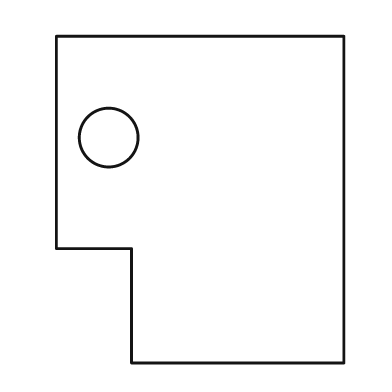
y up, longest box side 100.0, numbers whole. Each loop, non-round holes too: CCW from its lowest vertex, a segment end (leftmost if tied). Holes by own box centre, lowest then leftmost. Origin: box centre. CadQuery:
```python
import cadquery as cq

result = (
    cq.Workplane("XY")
    .moveTo(-21.0, -50.0)
    .lineTo(44.0, -50.0)
    .lineTo(44.0, 50.0)
    .lineTo(-44.0, 50.0)
    .lineTo(-44.0, -15.0)
    .lineTo(-21.0, -15.0)
    .close()
    .moveTo(-28.0, 19.0)
    .circle(9.0)
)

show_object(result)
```